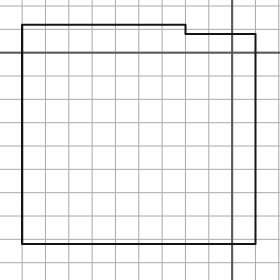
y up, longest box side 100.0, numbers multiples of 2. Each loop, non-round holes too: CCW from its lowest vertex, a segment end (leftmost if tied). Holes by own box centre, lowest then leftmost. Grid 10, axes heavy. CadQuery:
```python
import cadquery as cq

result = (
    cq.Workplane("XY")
    .moveTo(-90.0, -82.0)
    .lineTo(10.0, -82.0)
    .lineTo(10.0, 8.0)
    .lineTo(-20.0, 8.0)
    .lineTo(-20.0, 12.0)
    .lineTo(-90.0, 12.0)
    .close()
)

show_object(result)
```